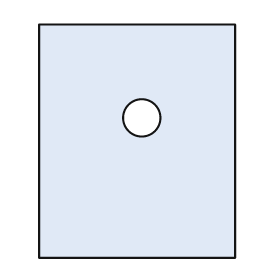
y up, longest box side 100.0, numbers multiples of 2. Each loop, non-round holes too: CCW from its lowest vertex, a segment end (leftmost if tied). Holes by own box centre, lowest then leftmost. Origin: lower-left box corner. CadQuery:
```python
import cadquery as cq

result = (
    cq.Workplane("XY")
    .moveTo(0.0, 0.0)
    .lineTo(84.0, 0.0)
    .lineTo(84.0, 100.0)
    .lineTo(0.0, 100.0)
    .close()
    .moveTo(44.0, 60.0)
    .circle(8.0)
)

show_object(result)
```